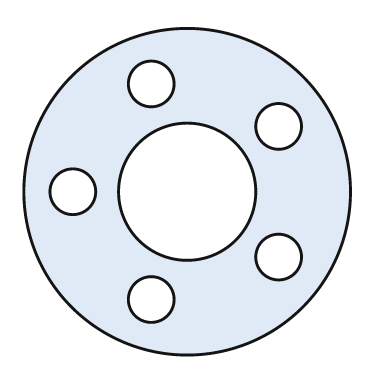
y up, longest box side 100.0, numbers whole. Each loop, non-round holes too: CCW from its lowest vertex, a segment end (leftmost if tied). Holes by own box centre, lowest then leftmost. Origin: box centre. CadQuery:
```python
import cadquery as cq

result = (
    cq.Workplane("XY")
    .moveTo(0.0, 0.0)
    .circle(50.0)
    .moveTo(-11.0, -33.0)
    .circle(7.0)
    .moveTo(28.0, -20.0)
    .circle(7.0)
    .moveTo(-35.0, 0.0)
    .circle(7.0)
    .moveTo(0.0, 0.0)
    .circle(21.0)
    .moveTo(28.0, 20.0)
    .circle(7.0)
    .moveTo(-11.0, 33.0)
    .circle(7.0)
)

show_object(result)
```